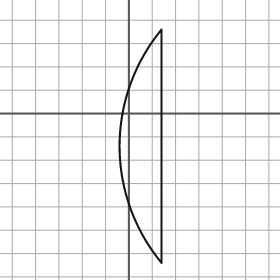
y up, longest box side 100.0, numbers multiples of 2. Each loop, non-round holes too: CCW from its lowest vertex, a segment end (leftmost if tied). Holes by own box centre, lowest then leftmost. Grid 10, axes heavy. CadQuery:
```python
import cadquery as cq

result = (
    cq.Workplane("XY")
    .moveTo(14.0, -64.0)
    .lineTo(14.0, 36.0)
    .threePointArc((-4.0, -14.0), (14.0, -64.0))
    .close()
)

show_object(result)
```